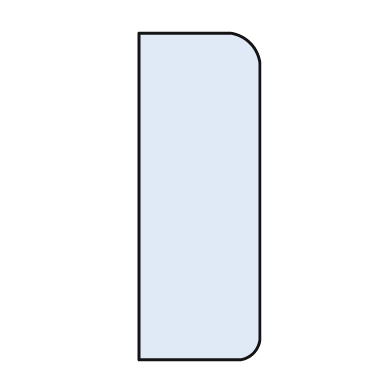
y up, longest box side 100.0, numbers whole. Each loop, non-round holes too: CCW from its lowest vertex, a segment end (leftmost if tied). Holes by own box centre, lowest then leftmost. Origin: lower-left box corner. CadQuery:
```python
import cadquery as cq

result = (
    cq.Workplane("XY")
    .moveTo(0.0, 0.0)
    .lineTo(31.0, 0.0)
    .threePointArc((35.0, 2.0), (37.0, 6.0))
    .lineTo(37.0, 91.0)
    .threePointArc((34.0, 97.0), (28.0, 100.0))
    .lineTo(0.0, 100.0)
    .close()
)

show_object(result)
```